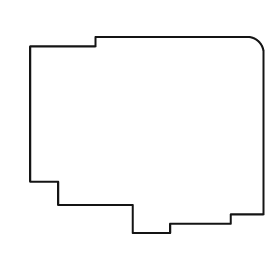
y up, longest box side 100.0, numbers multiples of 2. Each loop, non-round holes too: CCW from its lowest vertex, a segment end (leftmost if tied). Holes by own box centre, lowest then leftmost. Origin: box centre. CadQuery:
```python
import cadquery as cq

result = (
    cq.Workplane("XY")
    .moveTo(-6.0, -42.0)
    .lineTo(10.0, -42.0)
    .lineTo(10.0, -38.0)
    .lineTo(36.0, -38.0)
    .lineTo(36.0, -34.0)
    .lineTo(50.0, -34.0)
    .lineTo(50.0, 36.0)
    .threePointArc((48.0, 40.0), (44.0, 42.0))
    .lineTo(-22.0, 42.0)
    .lineTo(-22.0, 38.0)
    .lineTo(-50.0, 38.0)
    .lineTo(-50.0, -20.0)
    .lineTo(-38.0, -20.0)
    .lineTo(-38.0, -30.0)
    .lineTo(-6.0, -30.0)
    .close()
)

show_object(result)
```